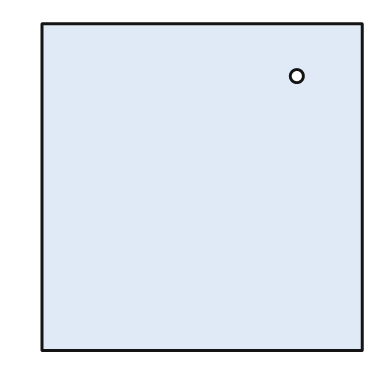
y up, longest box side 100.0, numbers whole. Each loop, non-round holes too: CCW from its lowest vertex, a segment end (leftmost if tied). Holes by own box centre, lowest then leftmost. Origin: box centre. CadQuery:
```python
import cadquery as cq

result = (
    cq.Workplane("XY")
    .moveTo(-49.0, -50.0)
    .lineTo(49.0, -50.0)
    .lineTo(49.0, 50.0)
    .lineTo(-49.0, 50.0)
    .close()
    .moveTo(29.0, 34.0)
    .circle(2.0)
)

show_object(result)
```